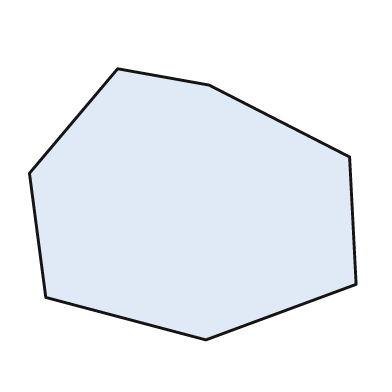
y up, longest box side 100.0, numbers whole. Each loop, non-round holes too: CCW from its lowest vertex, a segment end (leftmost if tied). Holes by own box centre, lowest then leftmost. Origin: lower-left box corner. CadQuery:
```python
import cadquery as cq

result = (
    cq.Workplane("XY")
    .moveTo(54.0, 0.0)
    .lineTo(100.0, 17.0)
    .lineTo(98.0, 56.0)
    .lineTo(55.0, 78.0)
    .lineTo(27.0, 83.0)
    .lineTo(0.0, 51.0)
    .lineTo(5.0, 13.0)
    .close()
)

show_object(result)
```